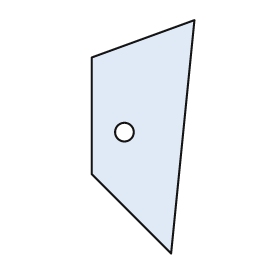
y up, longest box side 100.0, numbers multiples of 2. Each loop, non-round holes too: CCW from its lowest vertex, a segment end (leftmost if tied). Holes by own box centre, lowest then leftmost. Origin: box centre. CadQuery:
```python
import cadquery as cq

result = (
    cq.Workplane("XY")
    .moveTo(12.0, -50.0)
    .lineTo(22.0, 50.0)
    .lineTo(-22.0, 34.0)
    .lineTo(-22.0, -16.0)
    .close()
    .moveTo(-8.0, 2.0)
    .circle(4.0)
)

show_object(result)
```